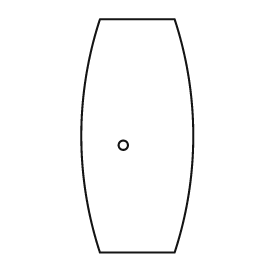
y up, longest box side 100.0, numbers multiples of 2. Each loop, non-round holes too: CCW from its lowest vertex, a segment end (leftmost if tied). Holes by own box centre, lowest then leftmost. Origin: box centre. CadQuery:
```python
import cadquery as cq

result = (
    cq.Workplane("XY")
    .moveTo(-16.0, -50.0)
    .lineTo(16.0, -50.0)
    .threePointArc((24.0, 0.0), (16.0, 50.0))
    .lineTo(-16.0, 50.0)
    .threePointArc((-24.0, 0.0), (-16.0, -50.0))
    .close()
    .moveTo(-6.0, -4.0)
    .circle(2.0)
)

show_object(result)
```